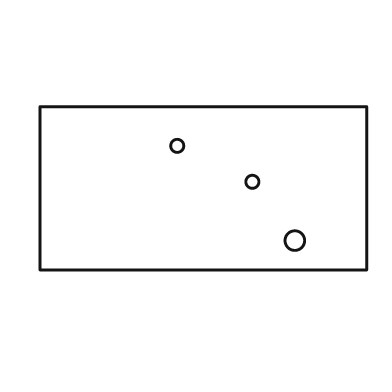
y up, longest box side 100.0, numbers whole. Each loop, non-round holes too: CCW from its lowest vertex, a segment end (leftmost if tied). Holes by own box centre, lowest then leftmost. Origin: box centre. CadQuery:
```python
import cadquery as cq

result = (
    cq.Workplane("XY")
    .moveTo(-50.0, -25.0)
    .lineTo(50.0, -25.0)
    .lineTo(50.0, 25.0)
    .lineTo(-50.0, 25.0)
    .close()
    .moveTo(28.0, -16.0)
    .circle(3.0)
    .moveTo(15.0, 2.0)
    .circle(2.0)
    .moveTo(-8.0, 13.0)
    .circle(2.0)
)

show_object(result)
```